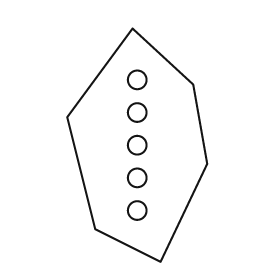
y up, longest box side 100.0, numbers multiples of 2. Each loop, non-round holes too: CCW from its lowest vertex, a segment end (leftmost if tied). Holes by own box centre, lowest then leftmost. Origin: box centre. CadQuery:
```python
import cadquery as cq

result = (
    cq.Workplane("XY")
    .moveTo(10.0, -50.0)
    .lineTo(30.0, -8.0)
    .lineTo(24.0, 26.0)
    .lineTo(-2.0, 50.0)
    .lineTo(-30.0, 12.0)
    .lineTo(-18.0, -36.0)
    .close()
    .moveTo(0.0, -28.0)
    .circle(4.0)
    .moveTo(0.0, -14.0)
    .circle(4.0)
    .moveTo(0.0, 0.0)
    .circle(4.0)
    .moveTo(0.0, 14.0)
    .circle(4.0)
    .moveTo(0.0, 28.0)
    .circle(4.0)
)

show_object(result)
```